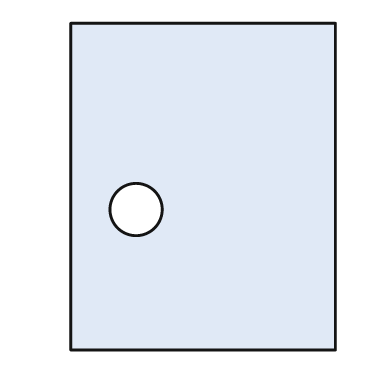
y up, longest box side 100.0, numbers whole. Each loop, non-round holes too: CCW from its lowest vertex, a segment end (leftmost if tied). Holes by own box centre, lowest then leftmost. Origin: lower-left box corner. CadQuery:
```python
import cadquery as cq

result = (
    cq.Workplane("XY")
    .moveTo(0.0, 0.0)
    .lineTo(81.0, 0.0)
    .lineTo(81.0, 100.0)
    .lineTo(0.0, 100.0)
    .close()
    .moveTo(20.0, 43.0)
    .circle(8.0)
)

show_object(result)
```